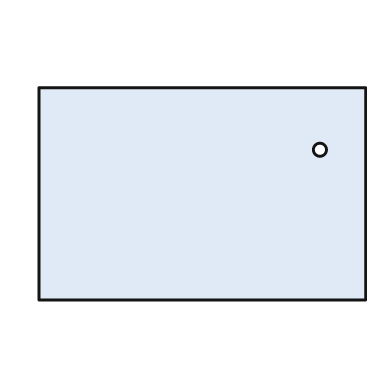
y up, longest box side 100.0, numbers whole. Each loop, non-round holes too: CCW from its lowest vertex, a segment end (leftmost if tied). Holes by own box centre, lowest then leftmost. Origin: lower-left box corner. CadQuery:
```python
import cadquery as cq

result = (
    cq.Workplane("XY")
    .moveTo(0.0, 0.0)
    .lineTo(100.0, 0.0)
    .lineTo(100.0, 65.0)
    .lineTo(0.0, 65.0)
    .close()
    .moveTo(86.0, 46.0)
    .circle(2.0)
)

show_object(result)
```